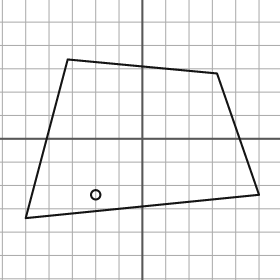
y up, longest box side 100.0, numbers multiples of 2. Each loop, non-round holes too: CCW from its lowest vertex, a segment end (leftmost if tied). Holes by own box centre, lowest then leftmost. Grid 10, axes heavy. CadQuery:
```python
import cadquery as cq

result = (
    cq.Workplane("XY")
    .moveTo(-50.0, -34.0)
    .lineTo(50.0, -24.0)
    .lineTo(32.0, 28.0)
    .lineTo(-32.0, 34.0)
    .close()
    .moveTo(-20.0, -24.0)
    .circle(2.0)
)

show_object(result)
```